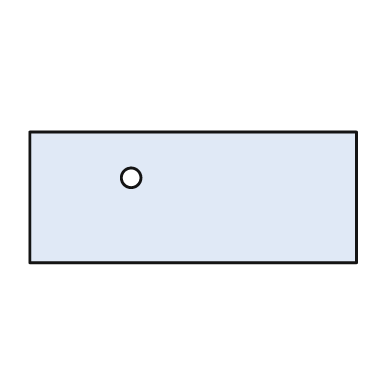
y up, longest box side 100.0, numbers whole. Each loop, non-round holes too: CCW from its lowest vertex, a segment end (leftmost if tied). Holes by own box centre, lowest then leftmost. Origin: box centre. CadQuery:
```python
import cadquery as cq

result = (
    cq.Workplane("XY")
    .moveTo(-50.0, -20.0)
    .lineTo(50.0, -20.0)
    .lineTo(50.0, 20.0)
    .lineTo(-50.0, 20.0)
    .close()
    .moveTo(-19.0, 6.0)
    .circle(3.0)
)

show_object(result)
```